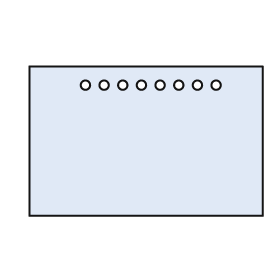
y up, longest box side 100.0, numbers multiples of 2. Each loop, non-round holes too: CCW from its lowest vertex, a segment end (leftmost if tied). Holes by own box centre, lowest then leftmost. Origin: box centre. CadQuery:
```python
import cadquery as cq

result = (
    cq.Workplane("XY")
    .moveTo(-50.0, -32.0)
    .lineTo(50.0, -32.0)
    .lineTo(50.0, 32.0)
    .lineTo(-50.0, 32.0)
    .close()
    .moveTo(-26.0, 24.0)
    .circle(2.0)
    .moveTo(-18.0, 24.0)
    .circle(2.0)
    .moveTo(-10.0, 24.0)
    .circle(2.0)
    .moveTo(-2.0, 24.0)
    .circle(2.0)
    .moveTo(6.0, 24.0)
    .circle(2.0)
    .moveTo(14.0, 24.0)
    .circle(2.0)
    .moveTo(22.0, 24.0)
    .circle(2.0)
    .moveTo(30.0, 24.0)
    .circle(2.0)
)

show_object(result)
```